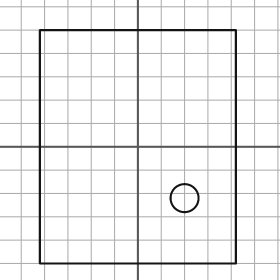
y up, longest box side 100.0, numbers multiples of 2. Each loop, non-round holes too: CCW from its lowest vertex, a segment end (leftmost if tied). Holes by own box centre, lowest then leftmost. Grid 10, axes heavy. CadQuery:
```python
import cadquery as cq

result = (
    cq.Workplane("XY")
    .moveTo(-42.0, -50.0)
    .lineTo(42.0, -50.0)
    .lineTo(42.0, 50.0)
    .lineTo(-42.0, 50.0)
    .close()
    .moveTo(20.0, -22.0)
    .circle(6.0)
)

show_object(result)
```